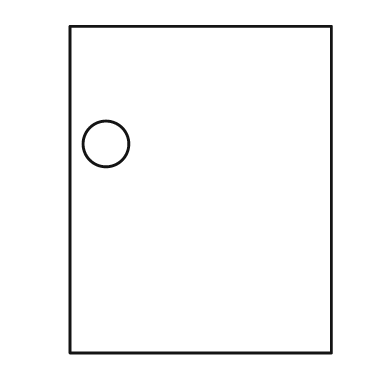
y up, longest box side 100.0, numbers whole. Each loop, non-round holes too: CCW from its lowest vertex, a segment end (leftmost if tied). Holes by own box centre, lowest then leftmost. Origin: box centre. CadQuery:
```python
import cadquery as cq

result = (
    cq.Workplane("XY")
    .moveTo(-40.0, -50.0)
    .lineTo(40.0, -50.0)
    .lineTo(40.0, 50.0)
    .lineTo(-40.0, 50.0)
    .close()
    .moveTo(-29.0, 14.0)
    .circle(7.0)
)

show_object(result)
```